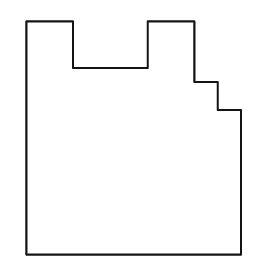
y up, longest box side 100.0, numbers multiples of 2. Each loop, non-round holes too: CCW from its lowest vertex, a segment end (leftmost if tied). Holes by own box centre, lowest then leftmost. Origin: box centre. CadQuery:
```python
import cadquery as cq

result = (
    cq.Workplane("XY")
    .moveTo(-46.0, -50.0)
    .lineTo(46.0, -50.0)
    .lineTo(46.0, 12.0)
    .lineTo(36.0, 12.0)
    .lineTo(36.0, 24.0)
    .lineTo(26.0, 24.0)
    .lineTo(26.0, 50.0)
    .lineTo(6.0, 50.0)
    .lineTo(6.0, 30.0)
    .lineTo(-26.0, 30.0)
    .lineTo(-26.0, 50.0)
    .lineTo(-46.0, 50.0)
    .close()
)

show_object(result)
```